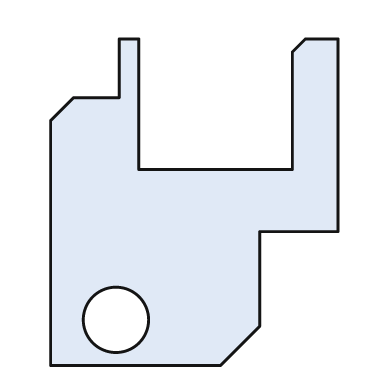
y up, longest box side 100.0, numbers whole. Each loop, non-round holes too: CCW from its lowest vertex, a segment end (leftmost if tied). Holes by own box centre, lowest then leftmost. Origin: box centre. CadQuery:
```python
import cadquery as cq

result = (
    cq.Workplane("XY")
    .moveTo(-44.0, -50.0)
    .lineTo(8.0, -50.0)
    .lineTo(20.0, -38.0)
    .lineTo(20.0, -9.0)
    .lineTo(44.0, -9.0)
    .lineTo(44.0, 50.0)
    .lineTo(34.0, 50.0)
    .lineTo(30.0, 46.0)
    .lineTo(30.0, 10.0)
    .lineTo(-17.0, 10.0)
    .lineTo(-17.0, 50.0)
    .lineTo(-23.0, 50.0)
    .lineTo(-23.0, 32.0)
    .lineTo(-37.0, 32.0)
    .lineTo(-44.0, 25.0)
    .close()
    .moveTo(-24.0, -36.0)
    .circle(10.0)
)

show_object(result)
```